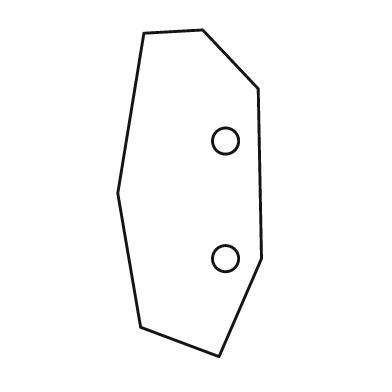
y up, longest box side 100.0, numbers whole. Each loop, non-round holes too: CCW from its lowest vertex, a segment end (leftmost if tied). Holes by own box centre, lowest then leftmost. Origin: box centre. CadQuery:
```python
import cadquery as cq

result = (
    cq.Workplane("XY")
    .moveTo(9.0, -50.0)
    .lineTo(22.0, -20.0)
    .lineTo(21.0, 32.0)
    .lineTo(4.0, 50.0)
    .lineTo(-14.0, 49.0)
    .lineTo(-22.0, 0.0)
    .lineTo(-15.0, -41.0)
    .close()
    .moveTo(11.0, -20.0)
    .circle(4.0)
    .moveTo(11.0, 16.0)
    .circle(4.0)
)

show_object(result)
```